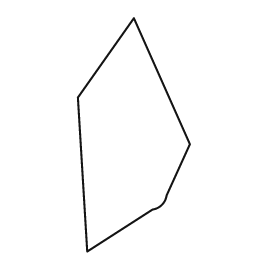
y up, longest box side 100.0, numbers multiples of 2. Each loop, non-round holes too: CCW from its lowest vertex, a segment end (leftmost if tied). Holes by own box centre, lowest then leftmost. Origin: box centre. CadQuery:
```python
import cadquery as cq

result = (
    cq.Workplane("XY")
    .moveTo(-20.0, -50.0)
    .lineTo(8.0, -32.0)
    .threePointArc((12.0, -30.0), (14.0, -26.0))
    .lineTo(24.0, -4.0)
    .lineTo(0.0, 50.0)
    .lineTo(-24.0, 16.0)
    .close()
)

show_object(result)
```